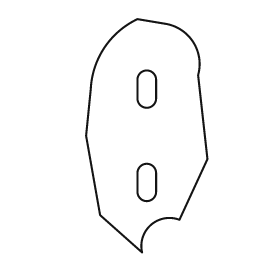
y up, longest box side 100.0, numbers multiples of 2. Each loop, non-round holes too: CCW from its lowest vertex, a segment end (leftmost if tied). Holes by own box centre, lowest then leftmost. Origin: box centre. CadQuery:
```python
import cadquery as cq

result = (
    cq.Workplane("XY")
    .moveTo(-2.0, -50.0)
    .threePointArc((2.0, -38.0), (14.0, -36.0))
    .lineTo(26.0, -10.0)
    .lineTo(22.0, 26.0)
    .threePointArc((20.0, 40.0), (8.0, 48.0))
    .lineTo(-4.0, 50.0)
    .threePointArc((-18.0, 38.0), (-24.0, 20.0))
    .lineTo(-26.0, 0.0)
    .lineTo(-20.0, -34.0)
    .close()
    .moveTo(-4.0, -24.0)
    .threePointArc((0.0, -28.0), (4.0, -24.0))
    .lineTo(4.0, -16.0)
    .threePointArc((0.0, -12.0), (-4.0, -16.0))
    .close()
    .moveTo(-4.0, 16.0)
    .threePointArc((0.0, 12.0), (4.0, 16.0))
    .lineTo(4.0, 24.0)
    .threePointArc((0.0, 28.0), (-4.0, 24.0))
    .close()
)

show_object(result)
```